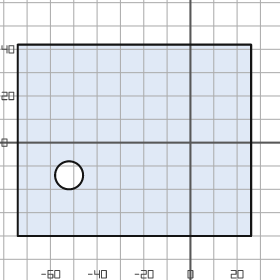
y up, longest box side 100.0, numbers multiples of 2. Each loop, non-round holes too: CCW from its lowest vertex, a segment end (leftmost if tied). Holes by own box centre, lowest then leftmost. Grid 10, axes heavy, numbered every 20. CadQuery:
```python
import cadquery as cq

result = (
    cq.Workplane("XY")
    .moveTo(-74.0, -40.0)
    .lineTo(26.0, -40.0)
    .lineTo(26.0, 42.0)
    .lineTo(-74.0, 42.0)
    .close()
    .moveTo(-52.0, -14.0)
    .circle(6.0)
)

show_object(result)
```